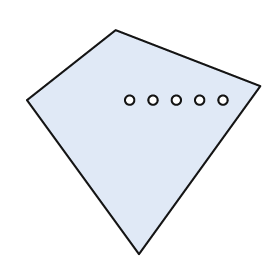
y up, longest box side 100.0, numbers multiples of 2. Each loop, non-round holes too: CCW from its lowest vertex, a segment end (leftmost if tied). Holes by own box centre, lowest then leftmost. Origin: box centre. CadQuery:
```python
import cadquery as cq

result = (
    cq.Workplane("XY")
    .moveTo(-2.0, -48.0)
    .lineTo(50.0, 24.0)
    .lineTo(-12.0, 48.0)
    .lineTo(-50.0, 18.0)
    .close()
    .moveTo(-6.0, 18.0)
    .circle(2.0)
    .moveTo(4.0, 18.0)
    .circle(2.0)
    .moveTo(14.0, 18.0)
    .circle(2.0)
    .moveTo(24.0, 18.0)
    .circle(2.0)
    .moveTo(34.0, 18.0)
    .circle(2.0)
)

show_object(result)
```